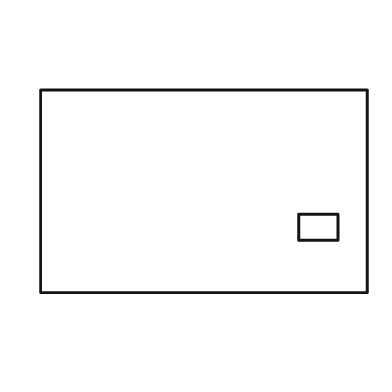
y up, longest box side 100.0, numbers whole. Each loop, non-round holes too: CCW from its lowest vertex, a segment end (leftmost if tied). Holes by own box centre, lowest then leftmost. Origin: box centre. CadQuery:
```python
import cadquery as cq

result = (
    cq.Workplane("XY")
    .moveTo(-50.0, -31.0)
    .lineTo(50.0, -31.0)
    .lineTo(50.0, 31.0)
    .lineTo(-50.0, 31.0)
    .close()
    .moveTo(29.0, -15.0)
    .lineTo(41.0, -15.0)
    .lineTo(41.0, -7.0)
    .lineTo(29.0, -7.0)
    .close()
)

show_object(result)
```